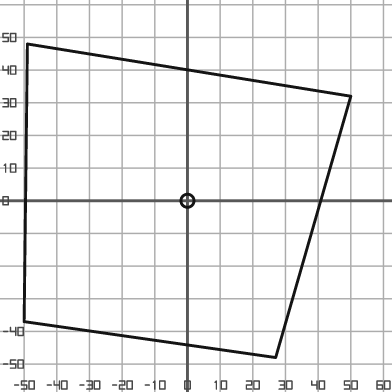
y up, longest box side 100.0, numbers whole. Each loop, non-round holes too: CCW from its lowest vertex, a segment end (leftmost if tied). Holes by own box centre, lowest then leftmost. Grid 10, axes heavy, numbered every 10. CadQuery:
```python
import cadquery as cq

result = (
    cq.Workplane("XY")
    .moveTo(27.0, -48.0)
    .lineTo(50.0, 32.0)
    .lineTo(-49.0, 48.0)
    .lineTo(-50.0, -37.0)
    .close()
    .moveTo(0.0, 0.0)
    .circle(2.0)
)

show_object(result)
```